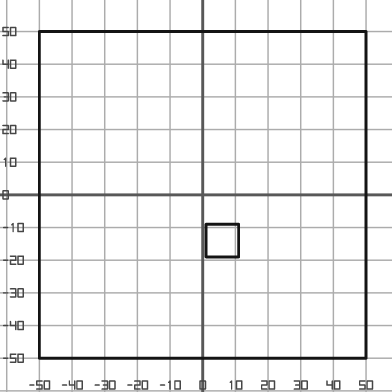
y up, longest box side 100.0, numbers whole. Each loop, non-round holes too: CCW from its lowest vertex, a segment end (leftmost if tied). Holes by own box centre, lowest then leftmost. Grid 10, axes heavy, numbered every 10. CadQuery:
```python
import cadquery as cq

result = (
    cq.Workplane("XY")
    .moveTo(-50.0, -50.0)
    .lineTo(50.0, -50.0)
    .lineTo(50.0, 50.0)
    .lineTo(-50.0, 50.0)
    .close()
    .moveTo(1.0, -19.0)
    .lineTo(11.0, -19.0)
    .lineTo(11.0, -9.0)
    .lineTo(1.0, -9.0)
    .close()
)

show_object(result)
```